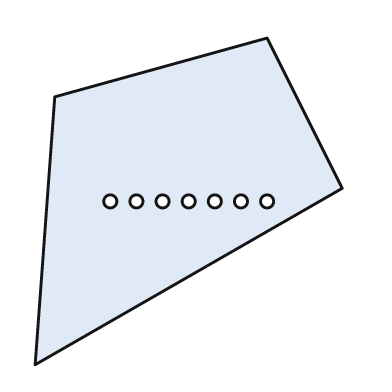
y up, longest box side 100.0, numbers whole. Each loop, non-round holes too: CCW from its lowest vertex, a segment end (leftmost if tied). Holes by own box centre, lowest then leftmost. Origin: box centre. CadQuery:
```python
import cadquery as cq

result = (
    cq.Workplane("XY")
    .moveTo(-47.0, -50.0)
    .lineTo(47.0, 4.0)
    .lineTo(24.0, 50.0)
    .lineTo(-41.0, 32.0)
    .close()
    .moveTo(-24.0, 0.0)
    .circle(2.0)
    .moveTo(-16.0, 0.0)
    .circle(2.0)
    .moveTo(-8.0, 0.0)
    .circle(2.0)
    .moveTo(0.0, 0.0)
    .circle(2.0)
    .moveTo(8.0, 0.0)
    .circle(2.0)
    .moveTo(16.0, 0.0)
    .circle(2.0)
    .moveTo(24.0, 0.0)
    .circle(2.0)
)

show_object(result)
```